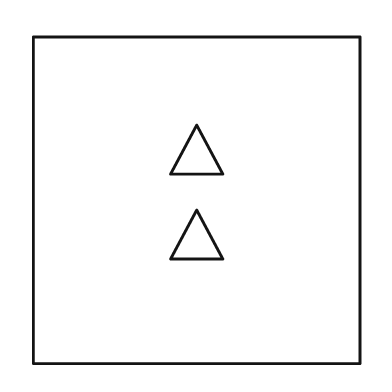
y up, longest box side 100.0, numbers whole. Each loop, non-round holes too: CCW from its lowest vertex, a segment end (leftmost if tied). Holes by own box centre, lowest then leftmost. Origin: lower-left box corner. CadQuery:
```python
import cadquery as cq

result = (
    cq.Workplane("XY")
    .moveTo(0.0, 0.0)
    .lineTo(100.0, 0.0)
    .lineTo(100.0, 100.0)
    .lineTo(0.0, 100.0)
    .close()
    .moveTo(42.0, 32.0)
    .lineTo(58.0, 32.0)
    .lineTo(50.0, 47.0)
    .close()
    .moveTo(42.0, 58.0)
    .lineTo(58.0, 58.0)
    .lineTo(50.0, 73.0)
    .close()
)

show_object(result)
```